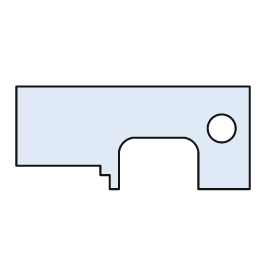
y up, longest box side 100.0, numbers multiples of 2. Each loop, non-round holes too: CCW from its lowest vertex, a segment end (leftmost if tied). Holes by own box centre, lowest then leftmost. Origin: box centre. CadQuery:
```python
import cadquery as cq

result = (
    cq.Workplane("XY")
    .moveTo(-10.0, -22.0)
    .lineTo(-6.0, -22.0)
    .lineTo(-6.0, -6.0)
    .threePointArc((-4.0, -2.0), (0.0, 0.0))
    .lineTo(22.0, 0.0)
    .threePointArc((26.0, -2.0), (28.0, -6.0))
    .lineTo(28.0, -22.0)
    .lineTo(50.0, -22.0)
    .lineTo(50.0, 22.0)
    .lineTo(-50.0, 22.0)
    .lineTo(-50.0, -12.0)
    .lineTo(-14.0, -12.0)
    .lineTo(-14.0, -16.0)
    .lineTo(-10.0, -16.0)
    .close()
    .moveTo(38.0, 4.0)
    .circle(6.0)
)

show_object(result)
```